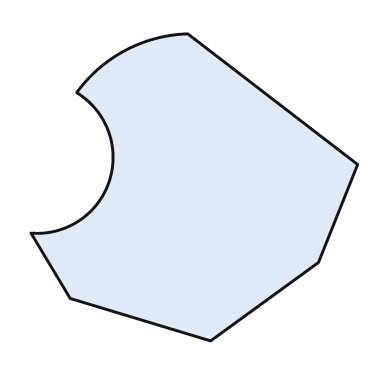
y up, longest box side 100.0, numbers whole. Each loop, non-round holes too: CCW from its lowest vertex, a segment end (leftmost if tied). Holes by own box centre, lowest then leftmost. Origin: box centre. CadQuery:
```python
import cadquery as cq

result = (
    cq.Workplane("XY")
    .moveTo(5.0, -47.0)
    .lineTo(38.0, -23.0)
    .lineTo(50.0, 7.0)
    .lineTo(-2.0, 47.0)
    .threePointArc((-21.0, 42.0), (-36.0, 29.0))
    .threePointArc((-26.0, 2.0), (-50.0, -14.0))
    .lineTo(-38.0, -34.0)
    .close()
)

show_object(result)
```